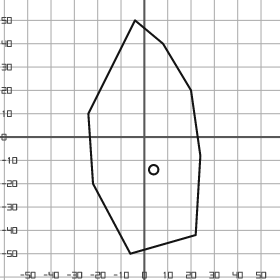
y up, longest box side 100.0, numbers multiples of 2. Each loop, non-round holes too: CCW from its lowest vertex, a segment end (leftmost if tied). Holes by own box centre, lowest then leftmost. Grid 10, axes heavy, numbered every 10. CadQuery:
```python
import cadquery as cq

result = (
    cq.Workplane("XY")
    .moveTo(-6.0, -50.0)
    .lineTo(22.0, -42.0)
    .lineTo(24.0, -8.0)
    .lineTo(20.0, 20.0)
    .lineTo(8.0, 40.0)
    .lineTo(-4.0, 50.0)
    .lineTo(-24.0, 10.0)
    .lineTo(-22.0, -20.0)
    .close()
    .moveTo(4.0, -14.0)
    .circle(2.0)
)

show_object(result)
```